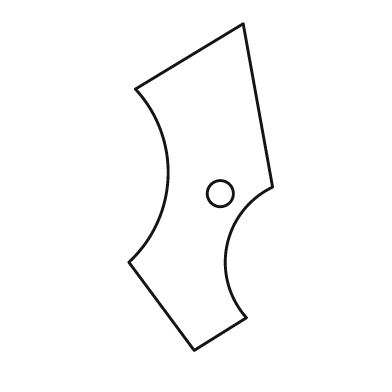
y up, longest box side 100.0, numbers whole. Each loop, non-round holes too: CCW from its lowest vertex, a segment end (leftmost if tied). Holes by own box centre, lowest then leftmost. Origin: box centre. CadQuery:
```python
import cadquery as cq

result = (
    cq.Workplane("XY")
    .moveTo(-2.0, -50.0)
    .lineTo(14.0, -40.0)
    .threePointArc((8.0, -18.0), (22.0, 0.0))
    .lineTo(13.0, 50.0)
    .lineTo(-20.0, 30.0)
    .threePointArc((-10.0, 3.0), (-22.0, -23.0))
    .close()
    .moveTo(6.0, -2.0)
    .circle(4.0)
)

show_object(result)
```